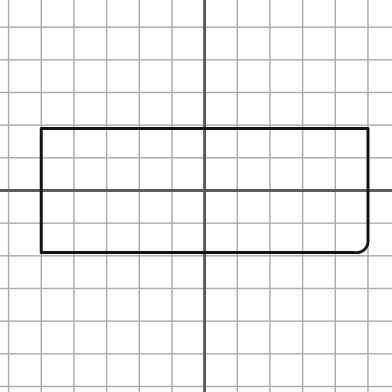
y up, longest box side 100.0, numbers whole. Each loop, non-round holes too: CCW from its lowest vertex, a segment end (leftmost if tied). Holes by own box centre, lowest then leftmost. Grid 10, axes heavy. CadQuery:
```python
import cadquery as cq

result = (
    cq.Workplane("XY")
    .moveTo(-50.0, -19.0)
    .lineTo(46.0, -19.0)
    .threePointArc((49.0, -18.0), (50.0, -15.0))
    .lineTo(50.0, 19.0)
    .lineTo(-50.0, 19.0)
    .close()
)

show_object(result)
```